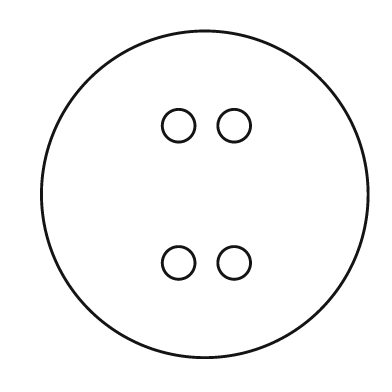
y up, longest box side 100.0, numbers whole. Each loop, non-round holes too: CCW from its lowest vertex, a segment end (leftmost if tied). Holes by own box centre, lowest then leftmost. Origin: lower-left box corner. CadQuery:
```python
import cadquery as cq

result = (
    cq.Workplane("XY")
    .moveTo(50.0, 50.0)
    .circle(50.0)
    .moveTo(42.0, 29.0)
    .circle(5.0)
    .moveTo(59.0, 29.0)
    .circle(5.0)
    .moveTo(42.0, 71.0)
    .circle(5.0)
    .moveTo(59.0, 71.0)
    .circle(5.0)
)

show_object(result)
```